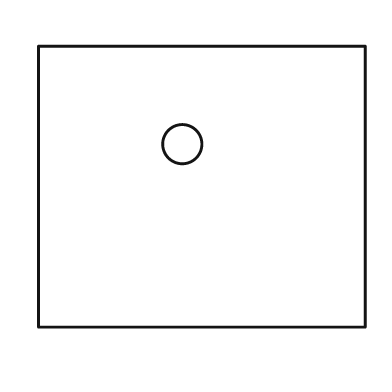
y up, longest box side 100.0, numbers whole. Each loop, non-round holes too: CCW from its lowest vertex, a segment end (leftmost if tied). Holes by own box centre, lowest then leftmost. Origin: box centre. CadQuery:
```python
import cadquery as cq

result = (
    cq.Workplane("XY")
    .moveTo(-50.0, -43.0)
    .lineTo(50.0, -43.0)
    .lineTo(50.0, 43.0)
    .lineTo(-50.0, 43.0)
    .close()
    .moveTo(-6.0, 13.0)
    .circle(6.0)
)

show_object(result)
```